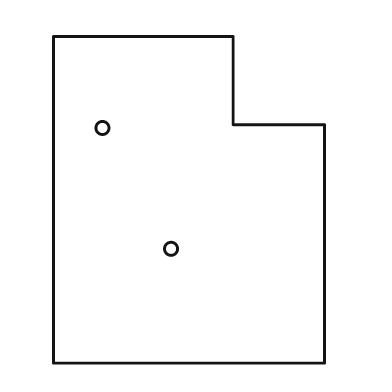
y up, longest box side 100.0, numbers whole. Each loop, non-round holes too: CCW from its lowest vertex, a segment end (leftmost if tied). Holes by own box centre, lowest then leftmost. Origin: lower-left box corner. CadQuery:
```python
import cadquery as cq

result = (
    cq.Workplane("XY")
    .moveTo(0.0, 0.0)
    .lineTo(83.0, 0.0)
    .lineTo(83.0, 73.0)
    .lineTo(55.0, 73.0)
    .lineTo(55.0, 100.0)
    .lineTo(0.0, 100.0)
    .close()
    .moveTo(36.0, 35.0)
    .circle(2.0)
    .moveTo(15.0, 72.0)
    .circle(2.0)
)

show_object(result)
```